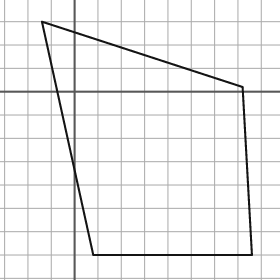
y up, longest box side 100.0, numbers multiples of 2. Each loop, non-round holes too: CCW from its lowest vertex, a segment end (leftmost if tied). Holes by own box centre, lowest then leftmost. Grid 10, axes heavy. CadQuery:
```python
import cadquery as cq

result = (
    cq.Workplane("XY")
    .moveTo(8.0, -70.0)
    .lineTo(76.0, -70.0)
    .lineTo(72.0, 2.0)
    .lineTo(-14.0, 30.0)
    .close()
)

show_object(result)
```